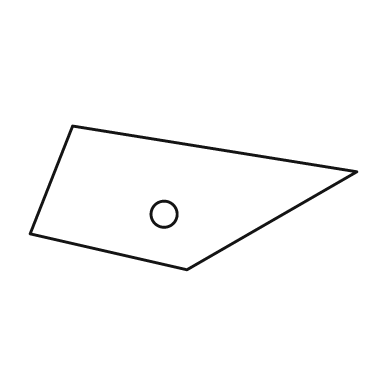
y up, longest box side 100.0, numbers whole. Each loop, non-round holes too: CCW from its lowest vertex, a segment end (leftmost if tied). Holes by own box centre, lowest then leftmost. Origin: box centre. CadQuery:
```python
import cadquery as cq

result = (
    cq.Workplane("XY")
    .moveTo(-2.0, -22.0)
    .lineTo(50.0, 8.0)
    .lineTo(-37.0, 22.0)
    .lineTo(-50.0, -11.0)
    .close()
    .moveTo(-9.0, -5.0)
    .circle(4.0)
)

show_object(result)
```